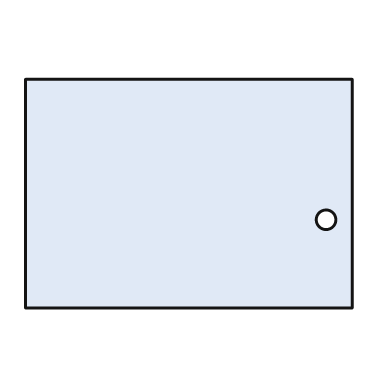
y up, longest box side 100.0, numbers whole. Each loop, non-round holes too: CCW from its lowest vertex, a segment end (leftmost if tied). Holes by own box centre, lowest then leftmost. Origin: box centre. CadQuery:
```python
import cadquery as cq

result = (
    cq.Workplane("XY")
    .moveTo(-50.0, -35.0)
    .lineTo(50.0, -35.0)
    .lineTo(50.0, 35.0)
    .lineTo(-50.0, 35.0)
    .close()
    .moveTo(42.0, -8.0)
    .circle(3.0)
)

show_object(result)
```